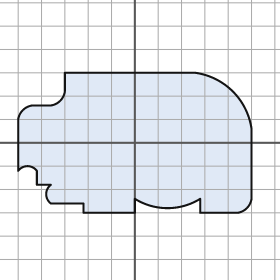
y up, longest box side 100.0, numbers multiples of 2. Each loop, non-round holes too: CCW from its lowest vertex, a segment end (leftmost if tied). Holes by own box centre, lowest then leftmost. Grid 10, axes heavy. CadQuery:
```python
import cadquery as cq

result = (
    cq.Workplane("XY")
    .moveTo(-22.0, -30.0)
    .lineTo(0.0, -30.0)
    .lineTo(0.0, -24.0)
    .threePointArc((14.0, -28.0), (28.0, -24.0))
    .lineTo(28.0, -30.0)
    .lineTo(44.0, -30.0)
    .threePointArc((48.0, -28.0), (50.0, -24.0))
    .lineTo(50.0, 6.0)
    .threePointArc((42.0, 22.0), (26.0, 30.0))
    .lineTo(-30.0, 30.0)
    .lineTo(-30.0, 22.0)
    .threePointArc((-32.0, 18.0), (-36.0, 16.0))
    .lineTo(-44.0, 16.0)
    .threePointArc((-48.0, 14.0), (-50.0, 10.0))
    .lineTo(-50.0, -12.0)
    .threePointArc((-46.0, -10.0), (-42.0, -12.0))
    .lineTo(-42.0, -18.0)
    .lineTo(-36.0, -18.0)
    .threePointArc((-38.0, -22.0), (-36.0, -26.0))
    .lineTo(-22.0, -26.0)
    .close()
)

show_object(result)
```